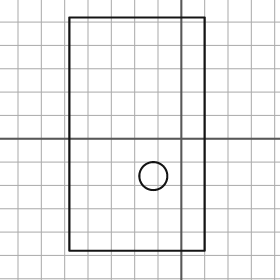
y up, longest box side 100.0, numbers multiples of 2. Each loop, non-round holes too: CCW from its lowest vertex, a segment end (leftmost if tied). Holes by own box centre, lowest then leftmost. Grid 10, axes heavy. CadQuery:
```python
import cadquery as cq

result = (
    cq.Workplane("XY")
    .moveTo(-48.0, -48.0)
    .lineTo(10.0, -48.0)
    .lineTo(10.0, 52.0)
    .lineTo(-48.0, 52.0)
    .close()
    .moveTo(-12.0, -16.0)
    .circle(6.0)
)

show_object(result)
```